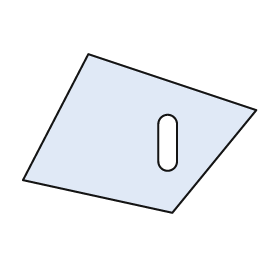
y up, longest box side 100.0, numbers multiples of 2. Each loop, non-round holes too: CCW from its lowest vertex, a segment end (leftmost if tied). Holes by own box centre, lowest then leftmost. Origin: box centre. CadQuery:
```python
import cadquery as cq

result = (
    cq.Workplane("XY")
    .moveTo(14.0, -34.0)
    .lineTo(50.0, 10.0)
    .lineTo(-22.0, 34.0)
    .lineTo(-50.0, -20.0)
    .close()
    .moveTo(8.0, -12.0)
    .threePointArc((12.0, -16.0), (16.0, -12.0))
    .lineTo(16.0, 4.0)
    .threePointArc((12.0, 8.0), (8.0, 4.0))
    .close()
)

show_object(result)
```